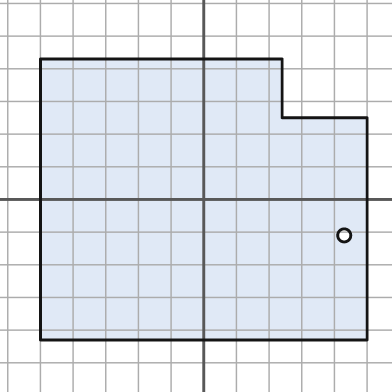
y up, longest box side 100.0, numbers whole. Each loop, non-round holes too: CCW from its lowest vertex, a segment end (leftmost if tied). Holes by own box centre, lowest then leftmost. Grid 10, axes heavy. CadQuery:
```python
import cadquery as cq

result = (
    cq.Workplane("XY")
    .moveTo(-50.0, -43.0)
    .lineTo(50.0, -43.0)
    .lineTo(50.0, 25.0)
    .lineTo(24.0, 25.0)
    .lineTo(24.0, 43.0)
    .lineTo(-50.0, 43.0)
    .close()
    .moveTo(43.0, -11.0)
    .circle(2.0)
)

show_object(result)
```